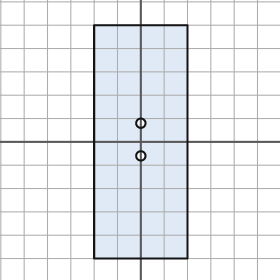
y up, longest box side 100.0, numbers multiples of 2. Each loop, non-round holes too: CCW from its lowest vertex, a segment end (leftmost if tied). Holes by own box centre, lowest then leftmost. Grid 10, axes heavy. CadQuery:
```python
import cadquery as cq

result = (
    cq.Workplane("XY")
    .moveTo(-20.0, -50.0)
    .lineTo(20.0, -50.0)
    .lineTo(20.0, 50.0)
    .lineTo(-20.0, 50.0)
    .close()
    .moveTo(0.0, -6.0)
    .circle(2.0)
    .moveTo(0.0, 8.0)
    .circle(2.0)
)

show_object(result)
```